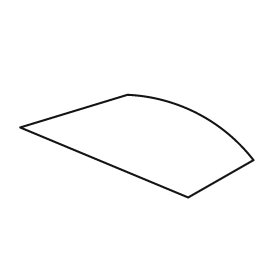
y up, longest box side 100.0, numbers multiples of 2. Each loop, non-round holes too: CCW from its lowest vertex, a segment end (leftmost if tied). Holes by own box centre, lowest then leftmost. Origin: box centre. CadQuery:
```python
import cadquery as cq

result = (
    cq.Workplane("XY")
    .moveTo(22.0, -22.0)
    .lineTo(50.0, -6.0)
    .threePointArc((26.0, 14.0), (-4.0, 22.0))
    .lineTo(-50.0, 8.0)
    .close()
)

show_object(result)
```